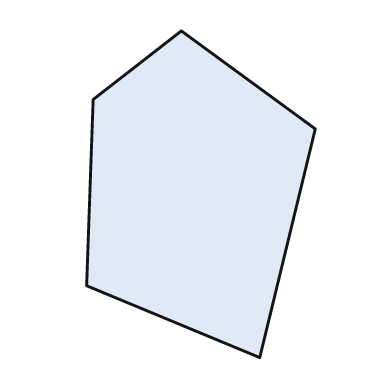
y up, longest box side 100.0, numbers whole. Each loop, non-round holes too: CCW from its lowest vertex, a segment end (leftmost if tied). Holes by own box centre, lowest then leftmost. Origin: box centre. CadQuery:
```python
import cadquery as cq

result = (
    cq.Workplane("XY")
    .moveTo(18.0, -50.0)
    .lineTo(35.0, 20.0)
    .lineTo(-6.0, 50.0)
    .lineTo(-33.0, 29.0)
    .lineTo(-35.0, -28.0)
    .close()
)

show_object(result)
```